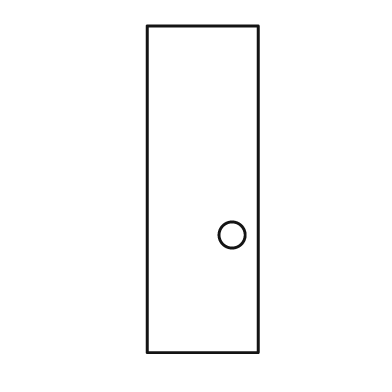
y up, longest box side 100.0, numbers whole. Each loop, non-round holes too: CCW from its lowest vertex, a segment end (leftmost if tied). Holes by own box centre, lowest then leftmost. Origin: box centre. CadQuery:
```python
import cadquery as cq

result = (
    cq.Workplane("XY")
    .moveTo(-17.0, -50.0)
    .lineTo(17.0, -50.0)
    .lineTo(17.0, 50.0)
    .lineTo(-17.0, 50.0)
    .close()
    .moveTo(9.0, -14.0)
    .circle(4.0)
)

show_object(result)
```